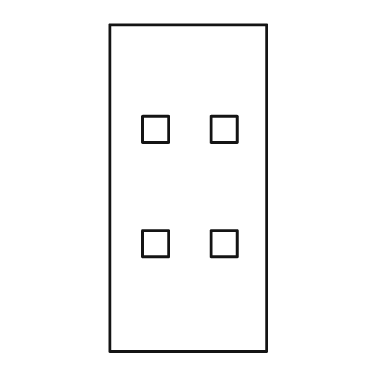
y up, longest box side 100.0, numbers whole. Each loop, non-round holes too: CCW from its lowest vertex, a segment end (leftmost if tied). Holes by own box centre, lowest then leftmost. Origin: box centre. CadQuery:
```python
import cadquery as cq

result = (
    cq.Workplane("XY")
    .moveTo(-24.0, -50.0)
    .lineTo(24.0, -50.0)
    .lineTo(24.0, 50.0)
    .lineTo(-24.0, 50.0)
    .close()
    .moveTo(-14.0, -21.0)
    .lineTo(-6.0, -21.0)
    .lineTo(-6.0, -13.0)
    .lineTo(-14.0, -13.0)
    .close()
    .moveTo(7.0, -21.0)
    .lineTo(15.0, -21.0)
    .lineTo(15.0, -13.0)
    .lineTo(7.0, -13.0)
    .close()
    .moveTo(-14.0, 14.0)
    .lineTo(-6.0, 14.0)
    .lineTo(-6.0, 22.0)
    .lineTo(-14.0, 22.0)
    .close()
    .moveTo(7.0, 14.0)
    .lineTo(15.0, 14.0)
    .lineTo(15.0, 22.0)
    .lineTo(7.0, 22.0)
    .close()
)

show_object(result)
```